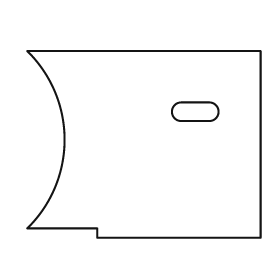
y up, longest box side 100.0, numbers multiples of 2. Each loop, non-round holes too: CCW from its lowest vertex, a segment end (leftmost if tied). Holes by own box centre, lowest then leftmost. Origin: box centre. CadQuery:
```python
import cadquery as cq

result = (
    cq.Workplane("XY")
    .moveTo(-20.0, -40.0)
    .lineTo(50.0, -40.0)
    .lineTo(50.0, 40.0)
    .lineTo(-50.0, 40.0)
    .threePointArc((-34.0, 2.0), (-50.0, -36.0))
    .lineTo(-20.0, -36.0)
    .close()
    .moveTo(16.0, 10.0)
    .lineTo(28.0, 10.0)
    .threePointArc((32.0, 14.0), (28.0, 18.0))
    .lineTo(16.0, 18.0)
    .threePointArc((12.0, 14.0), (16.0, 10.0))
    .close()
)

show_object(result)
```